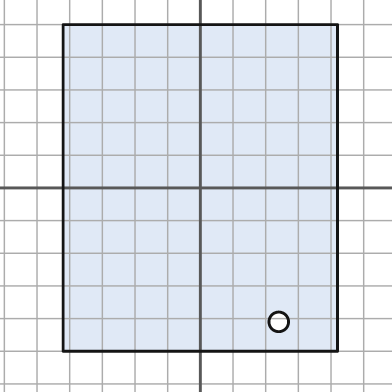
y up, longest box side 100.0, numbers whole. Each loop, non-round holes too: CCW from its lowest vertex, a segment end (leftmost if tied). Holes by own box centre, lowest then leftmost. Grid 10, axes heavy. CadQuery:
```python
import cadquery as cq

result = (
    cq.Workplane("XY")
    .moveTo(-42.0, -50.0)
    .lineTo(42.0, -50.0)
    .lineTo(42.0, 50.0)
    .lineTo(-42.0, 50.0)
    .close()
    .moveTo(24.0, -41.0)
    .circle(3.0)
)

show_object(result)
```